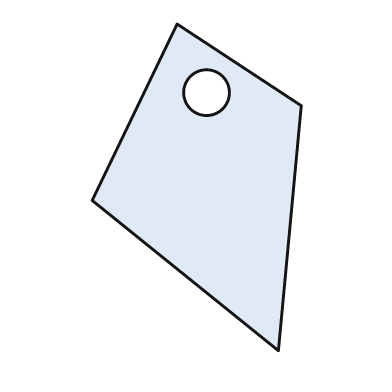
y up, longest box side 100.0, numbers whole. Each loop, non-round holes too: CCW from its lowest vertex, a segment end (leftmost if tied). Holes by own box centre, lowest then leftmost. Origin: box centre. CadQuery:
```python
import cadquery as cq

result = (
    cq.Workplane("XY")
    .moveTo(25.0, -50.0)
    .lineTo(32.0, 25.0)
    .lineTo(-6.0, 50.0)
    .lineTo(-32.0, -4.0)
    .close()
    .moveTo(3.0, 29.0)
    .circle(7.0)
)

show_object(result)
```